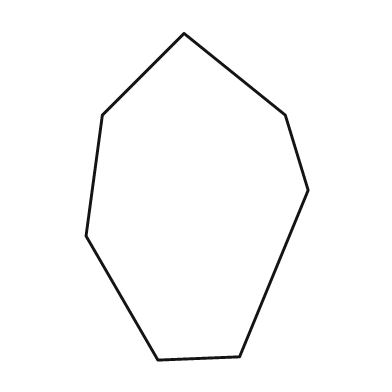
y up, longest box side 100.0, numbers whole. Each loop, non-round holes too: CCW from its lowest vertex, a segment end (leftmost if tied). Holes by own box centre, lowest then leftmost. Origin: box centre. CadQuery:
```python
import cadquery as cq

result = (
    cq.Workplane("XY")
    .moveTo(-12.0, -50.0)
    .lineTo(13.0, -49.0)
    .lineTo(34.0, 2.0)
    .lineTo(27.0, 25.0)
    .lineTo(-4.0, 50.0)
    .lineTo(-29.0, 25.0)
    .lineTo(-34.0, -12.0)
    .close()
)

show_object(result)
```